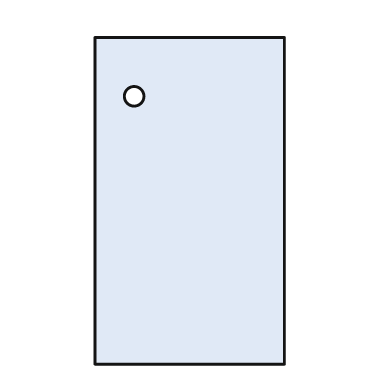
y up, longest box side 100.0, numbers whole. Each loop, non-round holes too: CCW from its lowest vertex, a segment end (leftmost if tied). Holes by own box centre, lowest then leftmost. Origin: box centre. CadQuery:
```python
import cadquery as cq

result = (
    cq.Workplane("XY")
    .moveTo(-29.0, -50.0)
    .lineTo(29.0, -50.0)
    .lineTo(29.0, 50.0)
    .lineTo(-29.0, 50.0)
    .close()
    .moveTo(-17.0, 32.0)
    .circle(3.0)
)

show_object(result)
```